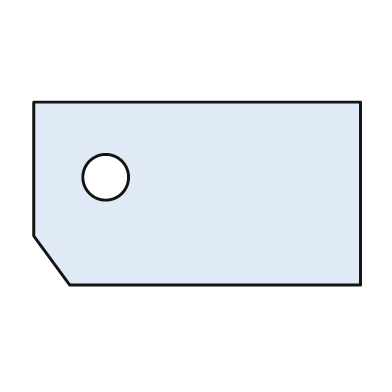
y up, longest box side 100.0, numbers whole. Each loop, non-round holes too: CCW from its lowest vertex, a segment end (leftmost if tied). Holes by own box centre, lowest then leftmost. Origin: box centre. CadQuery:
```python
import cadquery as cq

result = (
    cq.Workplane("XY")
    .moveTo(-39.0, -28.0)
    .lineTo(50.0, -28.0)
    .lineTo(50.0, 28.0)
    .lineTo(-50.0, 28.0)
    .lineTo(-50.0, -13.0)
    .close()
    .moveTo(-28.0, 5.0)
    .circle(7.0)
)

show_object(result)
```